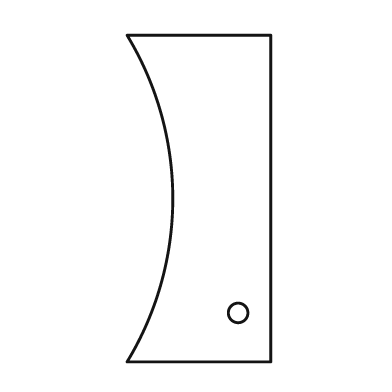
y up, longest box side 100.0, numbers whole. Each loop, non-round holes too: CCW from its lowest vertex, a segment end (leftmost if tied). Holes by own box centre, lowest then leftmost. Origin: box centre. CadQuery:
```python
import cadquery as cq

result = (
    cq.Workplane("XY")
    .moveTo(-22.0, -50.0)
    .lineTo(22.0, -50.0)
    .lineTo(22.0, 50.0)
    .lineTo(-22.0, 50.0)
    .threePointArc((-8.0, 0.0), (-22.0, -50.0))
    .close()
    .moveTo(12.0, -35.0)
    .circle(3.0)
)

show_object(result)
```